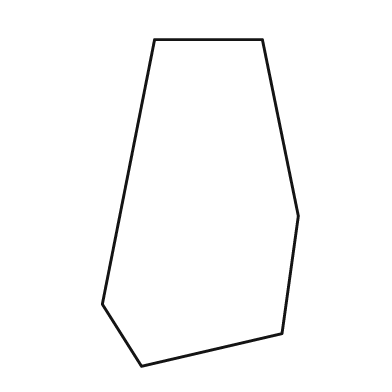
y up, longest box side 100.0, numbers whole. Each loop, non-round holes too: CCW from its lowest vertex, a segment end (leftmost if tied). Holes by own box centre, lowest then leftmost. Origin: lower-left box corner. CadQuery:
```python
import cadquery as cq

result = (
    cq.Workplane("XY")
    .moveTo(12.0, 0.0)
    .lineTo(55.0, 10.0)
    .lineTo(60.0, 46.0)
    .lineTo(49.0, 100.0)
    .lineTo(16.0, 100.0)
    .lineTo(0.0, 19.0)
    .close()
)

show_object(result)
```